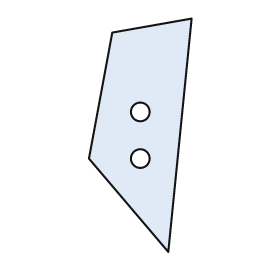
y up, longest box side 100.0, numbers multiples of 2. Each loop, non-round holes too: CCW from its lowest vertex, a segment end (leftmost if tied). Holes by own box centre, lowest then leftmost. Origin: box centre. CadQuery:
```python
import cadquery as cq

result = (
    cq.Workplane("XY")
    .moveTo(12.0, -50.0)
    .lineTo(22.0, 50.0)
    .lineTo(-12.0, 44.0)
    .lineTo(-22.0, -10.0)
    .close()
    .moveTo(0.0, -10.0)
    .circle(4.0)
    .moveTo(0.0, 10.0)
    .circle(4.0)
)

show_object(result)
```